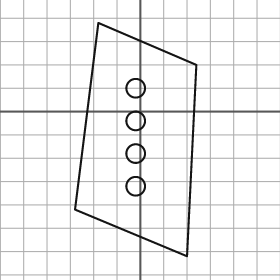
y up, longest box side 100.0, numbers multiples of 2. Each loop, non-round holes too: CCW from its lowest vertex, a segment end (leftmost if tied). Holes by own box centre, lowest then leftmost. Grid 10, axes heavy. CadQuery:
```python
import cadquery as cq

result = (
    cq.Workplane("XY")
    .moveTo(20.0, -62.0)
    .lineTo(24.0, 20.0)
    .lineTo(-18.0, 38.0)
    .lineTo(-28.0, -42.0)
    .close()
    .moveTo(-2.0, -32.0)
    .circle(4.0)
    .moveTo(-2.0, -18.0)
    .circle(4.0)
    .moveTo(-2.0, -4.0)
    .circle(4.0)
    .moveTo(-2.0, 10.0)
    .circle(4.0)
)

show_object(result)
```